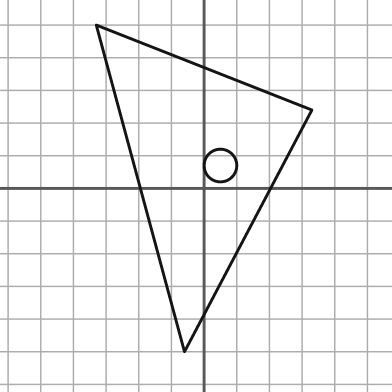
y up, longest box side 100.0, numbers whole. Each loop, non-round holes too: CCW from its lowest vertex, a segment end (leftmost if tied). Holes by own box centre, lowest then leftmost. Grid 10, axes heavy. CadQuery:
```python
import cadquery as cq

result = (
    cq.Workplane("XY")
    .moveTo(-6.0, -50.0)
    .lineTo(33.0, 24.0)
    .lineTo(-33.0, 50.0)
    .close()
    .moveTo(5.0, 7.0)
    .circle(5.0)
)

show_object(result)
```